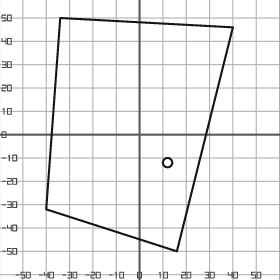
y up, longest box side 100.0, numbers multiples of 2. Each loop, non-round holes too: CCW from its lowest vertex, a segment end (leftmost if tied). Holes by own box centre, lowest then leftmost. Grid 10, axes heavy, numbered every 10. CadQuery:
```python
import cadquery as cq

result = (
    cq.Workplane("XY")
    .moveTo(16.0, -50.0)
    .lineTo(40.0, 46.0)
    .lineTo(-34.0, 50.0)
    .lineTo(-40.0, -32.0)
    .close()
    .moveTo(12.0, -12.0)
    .circle(2.0)
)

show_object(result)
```